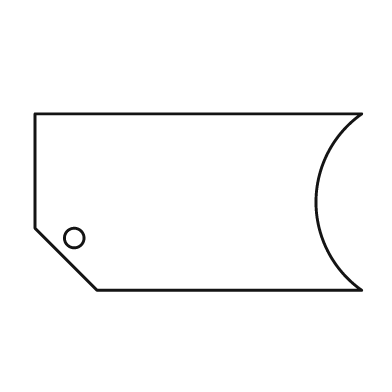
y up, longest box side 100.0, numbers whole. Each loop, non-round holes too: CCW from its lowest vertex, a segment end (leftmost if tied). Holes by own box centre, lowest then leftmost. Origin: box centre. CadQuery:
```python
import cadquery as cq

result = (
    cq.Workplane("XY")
    .moveTo(-31.0, -27.0)
    .lineTo(50.0, -27.0)
    .threePointArc((36.0, 0.0), (50.0, 27.0))
    .lineTo(-50.0, 27.0)
    .lineTo(-50.0, -8.0)
    .close()
    .moveTo(-38.0, -11.0)
    .circle(3.0)
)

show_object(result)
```